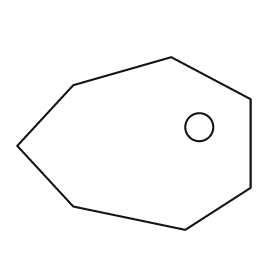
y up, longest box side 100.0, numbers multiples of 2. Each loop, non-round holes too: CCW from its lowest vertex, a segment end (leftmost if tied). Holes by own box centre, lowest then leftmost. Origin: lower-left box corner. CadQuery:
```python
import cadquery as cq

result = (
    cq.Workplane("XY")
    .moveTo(72.0, 0.0)
    .lineTo(100.0, 18.0)
    .lineTo(100.0, 56.0)
    .lineTo(66.0, 74.0)
    .lineTo(24.0, 62.0)
    .lineTo(0.0, 36.0)
    .lineTo(24.0, 10.0)
    .close()
    .moveTo(78.0, 44.0)
    .circle(6.0)
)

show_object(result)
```